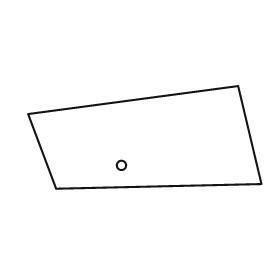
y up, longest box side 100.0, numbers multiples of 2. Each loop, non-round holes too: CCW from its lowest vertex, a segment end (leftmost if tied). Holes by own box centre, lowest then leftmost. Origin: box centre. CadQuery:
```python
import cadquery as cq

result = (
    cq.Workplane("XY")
    .moveTo(-38.0, -22.0)
    .lineTo(50.0, -20.0)
    .lineTo(40.0, 22.0)
    .lineTo(-50.0, 10.0)
    .close()
    .moveTo(-10.0, -12.0)
    .circle(2.0)
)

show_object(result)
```